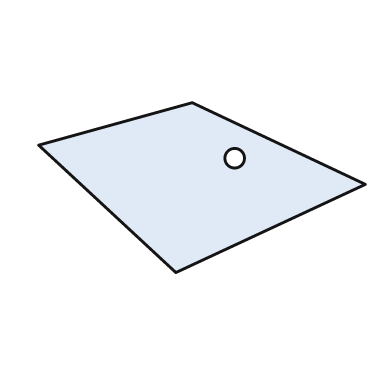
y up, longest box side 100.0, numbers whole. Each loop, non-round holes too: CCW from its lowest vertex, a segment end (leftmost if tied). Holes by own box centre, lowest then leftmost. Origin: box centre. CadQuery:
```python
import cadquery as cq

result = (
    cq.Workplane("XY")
    .moveTo(-8.0, -26.0)
    .lineTo(50.0, 1.0)
    .lineTo(-3.0, 26.0)
    .lineTo(-50.0, 13.0)
    .close()
    .moveTo(10.0, 9.0)
    .circle(3.0)
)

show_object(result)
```